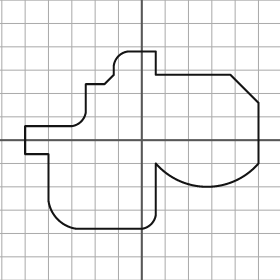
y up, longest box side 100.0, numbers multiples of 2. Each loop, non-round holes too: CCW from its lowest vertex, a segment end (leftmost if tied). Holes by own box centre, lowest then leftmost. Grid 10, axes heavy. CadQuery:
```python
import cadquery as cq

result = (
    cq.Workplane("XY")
    .moveTo(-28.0, -38.0)
    .lineTo(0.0, -38.0)
    .threePointArc((4.0, -36.0), (6.0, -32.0))
    .lineTo(6.0, -10.0)
    .threePointArc((28.0, -20.0), (50.0, -10.0))
    .lineTo(50.0, 16.0)
    .lineTo(38.0, 28.0)
    .lineTo(6.0, 28.0)
    .lineTo(6.0, 38.0)
    .lineTo(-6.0, 38.0)
    .threePointArc((-10.0, 36.0), (-12.0, 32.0))
    .lineTo(-12.0, 28.0)
    .lineTo(-16.0, 24.0)
    .lineTo(-24.0, 24.0)
    .lineTo(-24.0, 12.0)
    .threePointArc((-26.0, 8.0), (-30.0, 6.0))
    .lineTo(-50.0, 6.0)
    .lineTo(-50.0, -6.0)
    .lineTo(-40.0, -6.0)
    .lineTo(-40.0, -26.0)
    .threePointArc((-36.0, -34.0), (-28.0, -38.0))
    .close()
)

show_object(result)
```